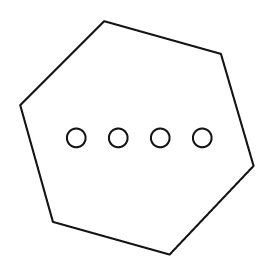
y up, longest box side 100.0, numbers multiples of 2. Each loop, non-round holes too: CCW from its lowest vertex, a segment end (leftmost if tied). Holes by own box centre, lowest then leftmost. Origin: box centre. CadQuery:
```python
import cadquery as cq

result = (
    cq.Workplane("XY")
    .moveTo(14.0, -50.0)
    .lineTo(50.0, -12.0)
    .lineTo(36.0, 36.0)
    .lineTo(-14.0, 50.0)
    .lineTo(-50.0, 14.0)
    .lineTo(-36.0, -36.0)
    .close()
    .moveTo(-26.0, 0.0)
    .circle(4.0)
    .moveTo(-8.0, 0.0)
    .circle(4.0)
    .moveTo(10.0, 0.0)
    .circle(4.0)
    .moveTo(28.0, 0.0)
    .circle(4.0)
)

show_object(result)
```